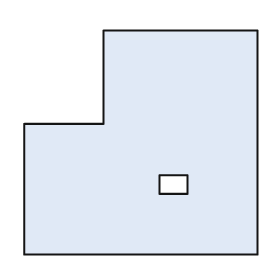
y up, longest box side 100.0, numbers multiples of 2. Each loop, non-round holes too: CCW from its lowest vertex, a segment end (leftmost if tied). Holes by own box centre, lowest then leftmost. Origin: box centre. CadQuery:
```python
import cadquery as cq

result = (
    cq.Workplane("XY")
    .moveTo(-50.0, -48.0)
    .lineTo(50.0, -48.0)
    .lineTo(50.0, 48.0)
    .lineTo(-16.0, 48.0)
    .lineTo(-16.0, 8.0)
    .lineTo(-50.0, 8.0)
    .close()
    .moveTo(8.0, -22.0)
    .lineTo(20.0, -22.0)
    .lineTo(20.0, -14.0)
    .lineTo(8.0, -14.0)
    .close()
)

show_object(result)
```